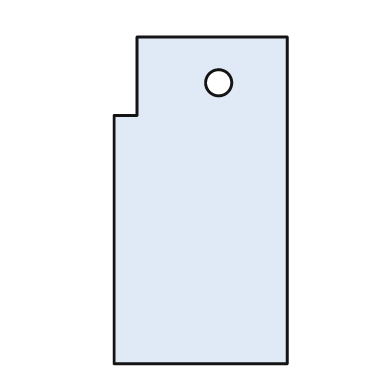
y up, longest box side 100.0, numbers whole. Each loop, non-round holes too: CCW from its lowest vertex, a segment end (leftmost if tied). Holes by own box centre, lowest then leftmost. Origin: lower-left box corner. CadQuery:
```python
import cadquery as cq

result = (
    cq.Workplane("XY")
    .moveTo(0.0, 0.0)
    .lineTo(53.0, 0.0)
    .lineTo(53.0, 100.0)
    .lineTo(7.0, 100.0)
    .lineTo(7.0, 76.0)
    .lineTo(0.0, 76.0)
    .close()
    .moveTo(32.0, 86.0)
    .circle(4.0)
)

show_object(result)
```